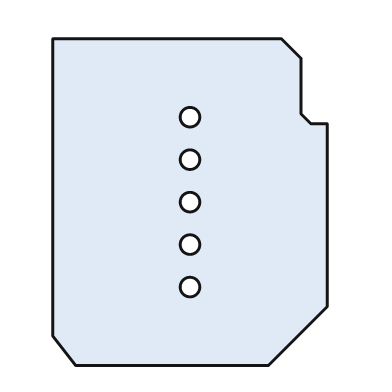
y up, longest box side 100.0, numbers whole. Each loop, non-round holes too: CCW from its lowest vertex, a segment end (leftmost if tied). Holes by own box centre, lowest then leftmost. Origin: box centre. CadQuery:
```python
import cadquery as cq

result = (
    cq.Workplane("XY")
    .moveTo(-35.0, -50.0)
    .lineTo(24.0, -50.0)
    .lineTo(42.0, -32.0)
    .lineTo(42.0, 24.0)
    .lineTo(37.0, 24.0)
    .lineTo(34.0, 27.0)
    .lineTo(34.0, 44.0)
    .lineTo(28.0, 50.0)
    .lineTo(-42.0, 50.0)
    .lineTo(-42.0, -41.0)
    .close()
    .moveTo(0.0, -26.0)
    .circle(3.0)
    .moveTo(0.0, -13.0)
    .circle(3.0)
    .moveTo(0.0, 0.0)
    .circle(3.0)
    .moveTo(0.0, 13.0)
    .circle(3.0)
    .moveTo(0.0, 26.0)
    .circle(3.0)
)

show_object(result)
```